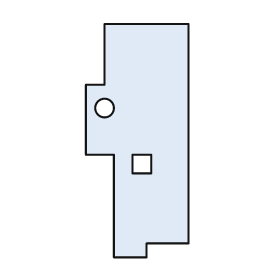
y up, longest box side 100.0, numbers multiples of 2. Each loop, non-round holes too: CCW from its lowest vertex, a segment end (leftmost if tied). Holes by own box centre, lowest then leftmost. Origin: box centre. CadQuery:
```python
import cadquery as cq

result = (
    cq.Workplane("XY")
    .moveTo(-10.0, -50.0)
    .lineTo(4.0, -50.0)
    .lineTo(4.0, -44.0)
    .lineTo(22.0, -44.0)
    .lineTo(22.0, 50.0)
    .lineTo(-14.0, 50.0)
    .lineTo(-14.0, 24.0)
    .lineTo(-22.0, 24.0)
    .lineTo(-22.0, -6.0)
    .lineTo(-10.0, -6.0)
    .close()
    .moveTo(-2.0, -14.0)
    .lineTo(6.0, -14.0)
    .lineTo(6.0, -6.0)
    .lineTo(-2.0, -6.0)
    .close()
    .moveTo(-14.0, 14.0)
    .circle(4.0)
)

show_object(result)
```